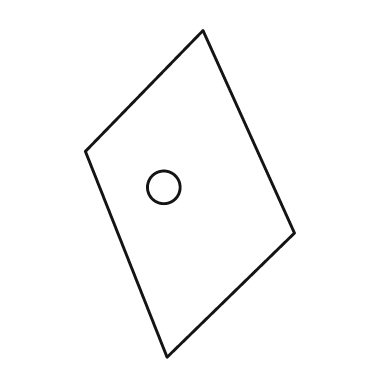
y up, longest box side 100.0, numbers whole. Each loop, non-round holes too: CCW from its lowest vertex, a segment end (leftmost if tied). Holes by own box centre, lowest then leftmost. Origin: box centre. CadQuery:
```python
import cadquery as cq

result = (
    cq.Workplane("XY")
    .moveTo(-7.0, -50.0)
    .lineTo(32.0, -12.0)
    .lineTo(4.0, 50.0)
    .lineTo(-32.0, 13.0)
    .close()
    .moveTo(-8.0, 2.0)
    .circle(5.0)
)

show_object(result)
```